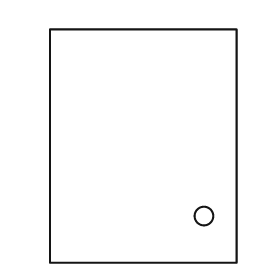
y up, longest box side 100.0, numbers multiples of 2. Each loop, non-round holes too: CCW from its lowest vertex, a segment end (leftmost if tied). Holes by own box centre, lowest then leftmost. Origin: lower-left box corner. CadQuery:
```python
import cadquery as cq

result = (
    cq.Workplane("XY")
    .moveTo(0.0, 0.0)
    .lineTo(80.0, 0.0)
    .lineTo(80.0, 100.0)
    .lineTo(0.0, 100.0)
    .close()
    .moveTo(66.0, 20.0)
    .circle(4.0)
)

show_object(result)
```